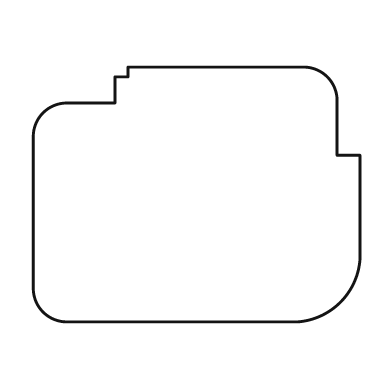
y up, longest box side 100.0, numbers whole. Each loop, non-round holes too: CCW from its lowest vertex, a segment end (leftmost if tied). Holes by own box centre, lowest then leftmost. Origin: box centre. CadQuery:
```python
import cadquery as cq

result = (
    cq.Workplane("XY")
    .moveTo(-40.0, -39.0)
    .lineTo(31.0, -39.0)
    .threePointArc((44.0, -33.0), (50.0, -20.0))
    .lineTo(50.0, 12.0)
    .lineTo(43.0, 12.0)
    .lineTo(43.0, 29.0)
    .threePointArc((40.0, 36.0), (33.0, 39.0))
    .lineTo(-21.0, 39.0)
    .lineTo(-21.0, 36.0)
    .lineTo(-25.0, 36.0)
    .lineTo(-25.0, 28.0)
    .lineTo(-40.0, 28.0)
    .threePointArc((-47.0, 25.0), (-50.0, 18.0))
    .lineTo(-50.0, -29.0)
    .threePointArc((-47.0, -36.0), (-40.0, -39.0))
    .close()
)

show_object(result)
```